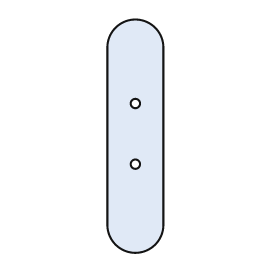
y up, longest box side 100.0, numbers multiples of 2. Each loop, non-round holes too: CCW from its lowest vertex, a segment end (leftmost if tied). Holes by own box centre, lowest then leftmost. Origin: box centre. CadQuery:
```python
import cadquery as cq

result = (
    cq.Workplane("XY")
    .moveTo(-12.0, -38.0)
    .threePointArc((0.0, -50.0), (12.0, -38.0))
    .lineTo(12.0, 38.0)
    .threePointArc((0.0, 50.0), (-12.0, 38.0))
    .close()
    .moveTo(0.0, -12.0)
    .circle(2.0)
    .moveTo(0.0, 14.0)
    .circle(2.0)
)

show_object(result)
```